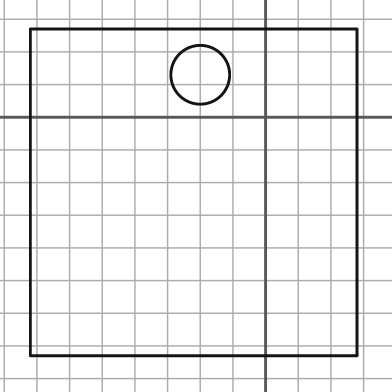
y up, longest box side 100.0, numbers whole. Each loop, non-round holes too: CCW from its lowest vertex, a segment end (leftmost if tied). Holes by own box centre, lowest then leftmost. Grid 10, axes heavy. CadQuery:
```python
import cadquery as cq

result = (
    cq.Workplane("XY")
    .moveTo(-72.0, -73.0)
    .lineTo(28.0, -73.0)
    .lineTo(28.0, 27.0)
    .lineTo(-72.0, 27.0)
    .close()
    .moveTo(-20.0, 13.0)
    .circle(9.0)
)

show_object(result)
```